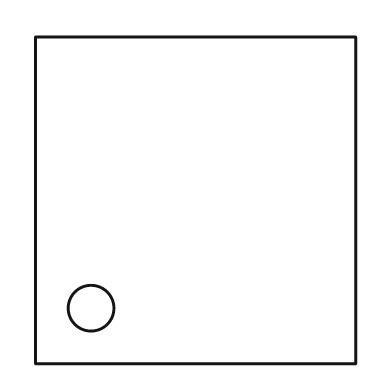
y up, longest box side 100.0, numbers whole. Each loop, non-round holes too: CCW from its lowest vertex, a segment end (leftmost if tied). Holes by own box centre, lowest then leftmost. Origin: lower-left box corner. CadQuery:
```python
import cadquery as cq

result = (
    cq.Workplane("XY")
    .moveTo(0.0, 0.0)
    .lineTo(98.0, 0.0)
    .lineTo(98.0, 100.0)
    .lineTo(0.0, 100.0)
    .close()
    .moveTo(17.0, 17.0)
    .circle(7.0)
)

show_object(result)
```